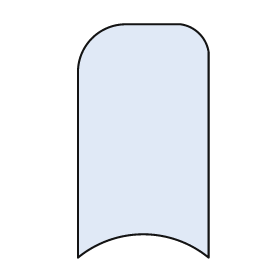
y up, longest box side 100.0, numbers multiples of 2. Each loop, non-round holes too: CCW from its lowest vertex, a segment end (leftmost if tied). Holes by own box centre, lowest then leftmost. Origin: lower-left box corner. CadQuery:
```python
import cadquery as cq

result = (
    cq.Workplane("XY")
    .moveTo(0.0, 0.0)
    .threePointArc((28.0, 10.0), (56.0, 0.0))
    .lineTo(56.0, 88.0)
    .threePointArc((52.0, 96.0), (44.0, 100.0))
    .lineTo(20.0, 100.0)
    .threePointArc((6.0, 94.0), (0.0, 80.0))
    .close()
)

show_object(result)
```